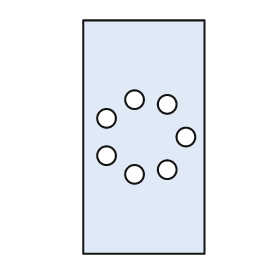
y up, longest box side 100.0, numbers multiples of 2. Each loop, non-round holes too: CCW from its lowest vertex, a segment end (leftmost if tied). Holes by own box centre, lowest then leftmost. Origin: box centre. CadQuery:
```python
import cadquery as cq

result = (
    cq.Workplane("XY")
    .moveTo(-26.0, -50.0)
    .lineTo(26.0, -50.0)
    .lineTo(26.0, 50.0)
    .lineTo(-26.0, 50.0)
    .close()
    .moveTo(-4.0, -16.0)
    .circle(4.0)
    .moveTo(10.0, -14.0)
    .circle(4.0)
    .moveTo(-16.0, -8.0)
    .circle(4.0)
    .moveTo(18.0, 0.0)
    .circle(4.0)
    .moveTo(-16.0, 8.0)
    .circle(4.0)
    .moveTo(10.0, 14.0)
    .circle(4.0)
    .moveTo(-4.0, 16.0)
    .circle(4.0)
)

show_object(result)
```